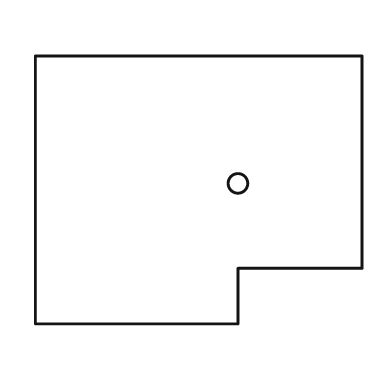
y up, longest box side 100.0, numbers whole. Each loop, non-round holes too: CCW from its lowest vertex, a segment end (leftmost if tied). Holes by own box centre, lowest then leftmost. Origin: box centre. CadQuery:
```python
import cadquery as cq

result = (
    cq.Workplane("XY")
    .moveTo(-50.0, -41.0)
    .lineTo(12.0, -41.0)
    .lineTo(12.0, -24.0)
    .lineTo(50.0, -24.0)
    .lineTo(50.0, 41.0)
    .lineTo(-50.0, 41.0)
    .close()
    .moveTo(12.0, 2.0)
    .circle(3.0)
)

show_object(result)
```